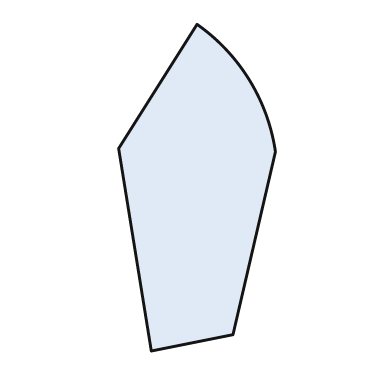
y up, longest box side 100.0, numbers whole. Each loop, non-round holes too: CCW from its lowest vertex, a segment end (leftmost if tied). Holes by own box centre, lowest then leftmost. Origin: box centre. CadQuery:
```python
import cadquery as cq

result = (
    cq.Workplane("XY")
    .moveTo(-14.0, -50.0)
    .lineTo(11.0, -45.0)
    .lineTo(24.0, 11.0)
    .threePointArc((16.0, 33.0), (0.0, 50.0))
    .lineTo(-24.0, 12.0)
    .close()
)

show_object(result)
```